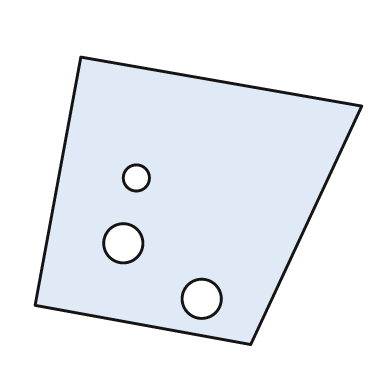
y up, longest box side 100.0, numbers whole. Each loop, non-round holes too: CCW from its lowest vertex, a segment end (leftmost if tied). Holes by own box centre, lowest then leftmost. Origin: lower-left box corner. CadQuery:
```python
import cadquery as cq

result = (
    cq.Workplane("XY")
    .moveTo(66.0, 0.0)
    .lineTo(100.0, 73.0)
    .lineTo(14.0, 88.0)
    .lineTo(0.0, 12.0)
    .close()
    .moveTo(51.0, 14.0)
    .circle(6.0)
    .moveTo(27.0, 31.0)
    .circle(6.0)
    .moveTo(31.0, 51.0)
    .circle(4.0)
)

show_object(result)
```